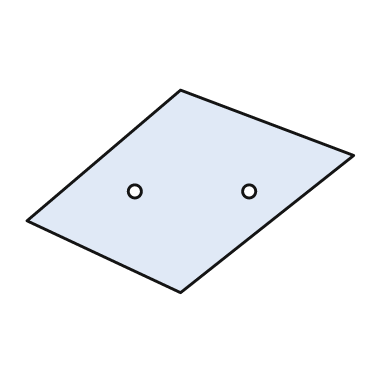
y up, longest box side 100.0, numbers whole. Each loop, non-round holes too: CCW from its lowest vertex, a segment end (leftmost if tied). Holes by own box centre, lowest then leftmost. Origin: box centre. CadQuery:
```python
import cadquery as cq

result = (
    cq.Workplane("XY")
    .moveTo(-3.0, -31.0)
    .lineTo(50.0, 11.0)
    .lineTo(-3.0, 31.0)
    .lineTo(-50.0, -9.0)
    .close()
    .moveTo(-17.0, 0.0)
    .circle(2.0)
    .moveTo(18.0, 0.0)
    .circle(2.0)
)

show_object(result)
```